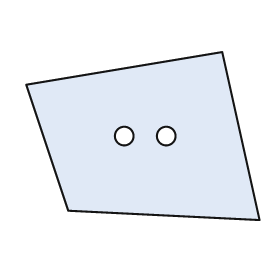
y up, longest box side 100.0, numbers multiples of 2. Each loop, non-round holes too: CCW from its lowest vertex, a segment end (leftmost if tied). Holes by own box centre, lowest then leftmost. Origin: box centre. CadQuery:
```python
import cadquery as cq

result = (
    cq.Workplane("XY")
    .moveTo(50.0, -36.0)
    .lineTo(34.0, 36.0)
    .lineTo(-50.0, 22.0)
    .lineTo(-32.0, -32.0)
    .close()
    .moveTo(-8.0, 0.0)
    .circle(4.0)
    .moveTo(10.0, 0.0)
    .circle(4.0)
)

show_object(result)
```